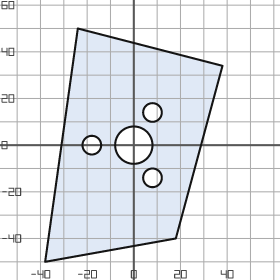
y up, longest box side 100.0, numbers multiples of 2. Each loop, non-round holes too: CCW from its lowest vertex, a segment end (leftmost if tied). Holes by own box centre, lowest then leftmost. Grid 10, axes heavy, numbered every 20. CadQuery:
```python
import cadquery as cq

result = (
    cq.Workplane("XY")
    .moveTo(-38.0, -50.0)
    .lineTo(18.0, -40.0)
    .lineTo(38.0, 34.0)
    .lineTo(-24.0, 50.0)
    .close()
    .moveTo(8.0, -14.0)
    .circle(4.0)
    .moveTo(-18.0, 0.0)
    .circle(4.0)
    .moveTo(0.0, 0.0)
    .circle(8.0)
    .moveTo(8.0, 14.0)
    .circle(4.0)
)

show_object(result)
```